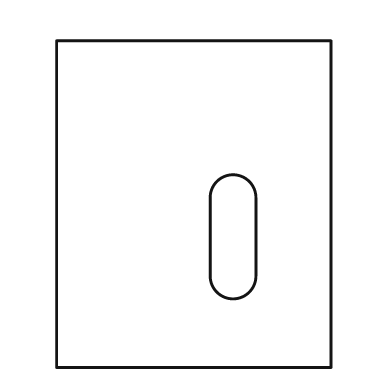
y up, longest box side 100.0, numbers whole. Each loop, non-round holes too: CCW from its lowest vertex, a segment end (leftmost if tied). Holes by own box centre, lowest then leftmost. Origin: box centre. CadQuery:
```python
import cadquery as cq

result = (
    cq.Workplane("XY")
    .moveTo(-42.0, -50.0)
    .lineTo(42.0, -50.0)
    .lineTo(42.0, 50.0)
    .lineTo(-42.0, 50.0)
    .close()
    .moveTo(5.0, -22.0)
    .threePointArc((12.0, -29.0), (19.0, -22.0))
    .lineTo(19.0, 2.0)
    .threePointArc((12.0, 9.0), (5.0, 2.0))
    .close()
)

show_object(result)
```